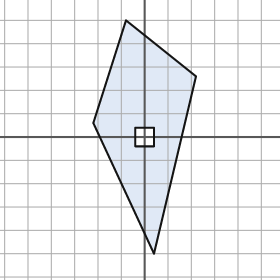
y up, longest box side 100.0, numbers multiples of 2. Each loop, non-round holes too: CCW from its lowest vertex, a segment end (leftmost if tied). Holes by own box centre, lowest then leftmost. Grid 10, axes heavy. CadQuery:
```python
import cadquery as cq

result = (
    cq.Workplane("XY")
    .moveTo(4.0, -50.0)
    .lineTo(22.0, 26.0)
    .lineTo(-8.0, 50.0)
    .lineTo(-22.0, 6.0)
    .close()
    .moveTo(-4.0, -4.0)
    .lineTo(4.0, -4.0)
    .lineTo(4.0, 4.0)
    .lineTo(-4.0, 4.0)
    .close()
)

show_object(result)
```